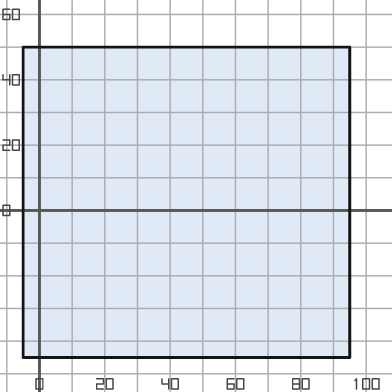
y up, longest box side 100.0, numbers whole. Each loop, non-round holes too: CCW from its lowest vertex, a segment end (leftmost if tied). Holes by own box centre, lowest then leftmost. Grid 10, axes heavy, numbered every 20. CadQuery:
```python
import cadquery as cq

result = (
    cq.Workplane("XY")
    .moveTo(-5.0, -45.0)
    .lineTo(95.0, -45.0)
    .lineTo(95.0, 50.0)
    .lineTo(-5.0, 50.0)
    .close()
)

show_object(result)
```